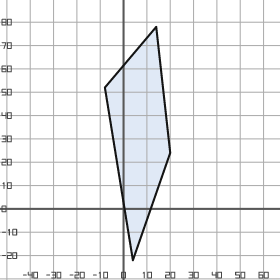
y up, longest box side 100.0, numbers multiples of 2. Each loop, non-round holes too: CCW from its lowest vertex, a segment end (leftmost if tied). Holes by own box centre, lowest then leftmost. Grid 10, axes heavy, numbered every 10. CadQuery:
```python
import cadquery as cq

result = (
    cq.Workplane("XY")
    .moveTo(4.0, -22.0)
    .lineTo(20.0, 24.0)
    .lineTo(14.0, 78.0)
    .lineTo(-8.0, 52.0)
    .close()
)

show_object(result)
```